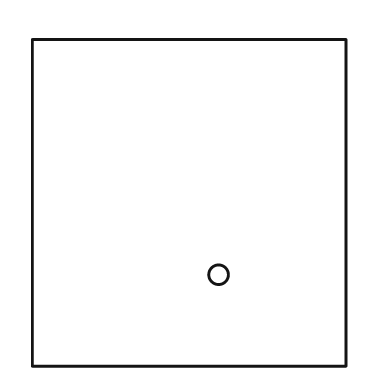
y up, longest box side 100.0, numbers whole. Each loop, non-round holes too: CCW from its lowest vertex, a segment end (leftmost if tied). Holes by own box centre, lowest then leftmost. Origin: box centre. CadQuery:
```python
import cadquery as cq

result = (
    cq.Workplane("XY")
    .moveTo(-48.0, -50.0)
    .lineTo(48.0, -50.0)
    .lineTo(48.0, 50.0)
    .lineTo(-48.0, 50.0)
    .close()
    .moveTo(9.0, -22.0)
    .circle(3.0)
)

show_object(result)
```